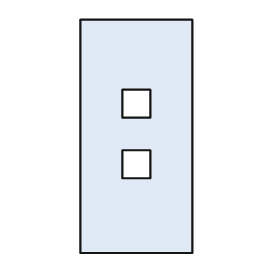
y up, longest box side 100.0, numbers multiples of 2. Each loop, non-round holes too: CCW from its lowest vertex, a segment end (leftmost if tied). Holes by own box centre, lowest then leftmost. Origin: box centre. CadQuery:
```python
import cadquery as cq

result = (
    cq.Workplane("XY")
    .moveTo(-24.0, -50.0)
    .lineTo(24.0, -50.0)
    .lineTo(24.0, 50.0)
    .lineTo(-24.0, 50.0)
    .close()
    .moveTo(-6.0, -18.0)
    .lineTo(6.0, -18.0)
    .lineTo(6.0, -6.0)
    .lineTo(-6.0, -6.0)
    .close()
    .moveTo(-6.0, 8.0)
    .lineTo(6.0, 8.0)
    .lineTo(6.0, 20.0)
    .lineTo(-6.0, 20.0)
    .close()
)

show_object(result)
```